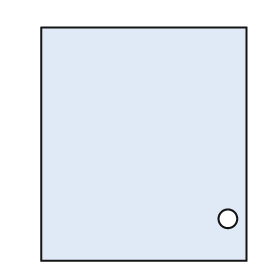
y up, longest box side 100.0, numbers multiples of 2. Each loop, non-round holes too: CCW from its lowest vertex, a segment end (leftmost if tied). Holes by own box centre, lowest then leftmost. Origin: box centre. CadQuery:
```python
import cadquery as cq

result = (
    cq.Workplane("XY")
    .moveTo(-44.0, -50.0)
    .lineTo(44.0, -50.0)
    .lineTo(44.0, 50.0)
    .lineTo(-44.0, 50.0)
    .close()
    .moveTo(36.0, -32.0)
    .circle(4.0)
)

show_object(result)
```